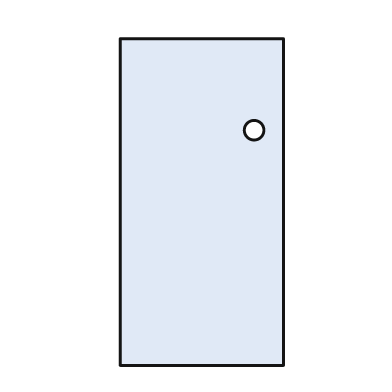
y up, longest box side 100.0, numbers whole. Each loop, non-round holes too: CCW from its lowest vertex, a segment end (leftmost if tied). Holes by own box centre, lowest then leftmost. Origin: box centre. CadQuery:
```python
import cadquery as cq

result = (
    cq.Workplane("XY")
    .moveTo(-25.0, -50.0)
    .lineTo(25.0, -50.0)
    .lineTo(25.0, 50.0)
    .lineTo(-25.0, 50.0)
    .close()
    .moveTo(16.0, 22.0)
    .circle(3.0)
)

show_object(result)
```